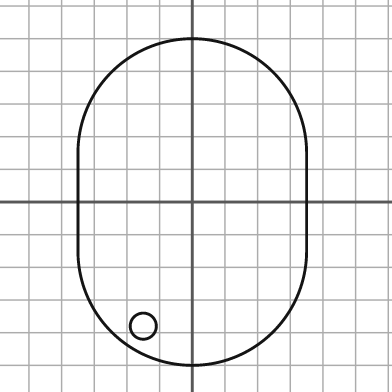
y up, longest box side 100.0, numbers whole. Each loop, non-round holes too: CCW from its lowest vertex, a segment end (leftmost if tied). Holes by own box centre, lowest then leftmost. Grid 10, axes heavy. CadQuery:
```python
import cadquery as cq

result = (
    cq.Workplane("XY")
    .moveTo(-35.0, -15.0)
    .threePointArc((0.0, -50.0), (35.0, -15.0))
    .lineTo(35.0, 15.0)
    .threePointArc((0.0, 50.0), (-35.0, 15.0))
    .close()
    .moveTo(-15.0, -38.0)
    .circle(4.0)
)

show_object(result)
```